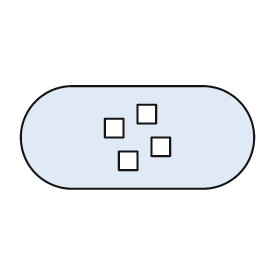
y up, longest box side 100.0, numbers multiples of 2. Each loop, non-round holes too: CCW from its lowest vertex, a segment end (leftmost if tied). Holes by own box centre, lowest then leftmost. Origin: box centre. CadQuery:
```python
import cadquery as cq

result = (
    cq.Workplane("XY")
    .moveTo(-28.0, -22.0)
    .lineTo(28.0, -22.0)
    .threePointArc((50.0, 0.0), (28.0, 22.0))
    .lineTo(-28.0, 22.0)
    .threePointArc((-50.0, 0.0), (-28.0, -22.0))
    .close()
    .moveTo(-8.0, -14.0)
    .lineTo(0.0, -14.0)
    .lineTo(0.0, -6.0)
    .lineTo(-8.0, -6.0)
    .close()
    .moveTo(6.0, -8.0)
    .lineTo(14.0, -8.0)
    .lineTo(14.0, 0.0)
    .lineTo(6.0, 0.0)
    .close()
    .moveTo(-14.0, 0.0)
    .lineTo(-6.0, 0.0)
    .lineTo(-6.0, 8.0)
    .lineTo(-14.0, 8.0)
    .close()
    .moveTo(0.0, 6.0)
    .lineTo(8.0, 6.0)
    .lineTo(8.0, 14.0)
    .lineTo(0.0, 14.0)
    .close()
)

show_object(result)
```